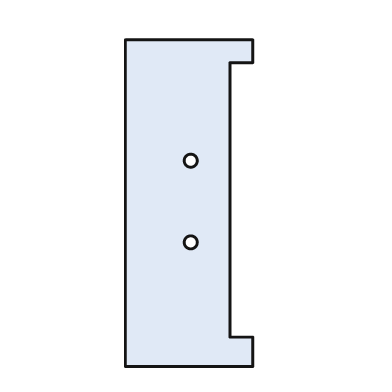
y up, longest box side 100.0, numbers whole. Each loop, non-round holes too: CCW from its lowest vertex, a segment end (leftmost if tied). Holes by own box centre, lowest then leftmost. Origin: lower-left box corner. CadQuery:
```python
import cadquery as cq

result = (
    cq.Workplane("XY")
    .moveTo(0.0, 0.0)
    .lineTo(39.0, 0.0)
    .lineTo(39.0, 9.0)
    .lineTo(32.0, 9.0)
    .lineTo(32.0, 93.0)
    .lineTo(39.0, 93.0)
    .lineTo(39.0, 100.0)
    .lineTo(0.0, 100.0)
    .close()
    .moveTo(20.0, 38.0)
    .circle(2.0)
    .moveTo(20.0, 63.0)
    .circle(2.0)
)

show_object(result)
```